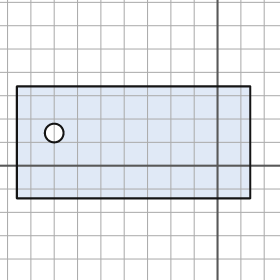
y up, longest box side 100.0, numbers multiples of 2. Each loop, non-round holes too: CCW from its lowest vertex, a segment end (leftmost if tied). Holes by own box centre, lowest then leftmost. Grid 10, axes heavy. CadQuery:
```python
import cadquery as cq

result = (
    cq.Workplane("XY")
    .moveTo(-86.0, -14.0)
    .lineTo(14.0, -14.0)
    .lineTo(14.0, 34.0)
    .lineTo(-86.0, 34.0)
    .close()
    .moveTo(-70.0, 14.0)
    .circle(4.0)
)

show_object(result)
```